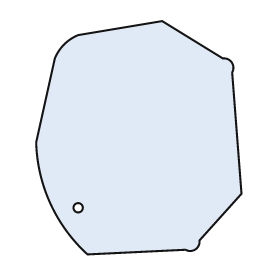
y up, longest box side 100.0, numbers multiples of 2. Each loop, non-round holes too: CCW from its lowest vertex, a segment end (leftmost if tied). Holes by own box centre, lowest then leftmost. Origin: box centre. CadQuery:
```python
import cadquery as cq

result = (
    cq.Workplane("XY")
    .moveTo(-22.0, -50.0)
    .lineTo(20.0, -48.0)
    .threePointArc((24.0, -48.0), (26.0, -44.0))
    .lineTo(44.0, -24.0)
    .lineTo(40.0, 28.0)
    .threePointArc((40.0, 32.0), (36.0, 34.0))
    .lineTo(10.0, 50.0)
    .lineTo(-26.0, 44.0)
    .threePointArc((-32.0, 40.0), (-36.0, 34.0))
    .lineTo(-44.0, -2.0)
    .threePointArc((-38.0, -28.0), (-22.0, -50.0))
    .close()
    .moveTo(-26.0, -30.0)
    .circle(2.0)
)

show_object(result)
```